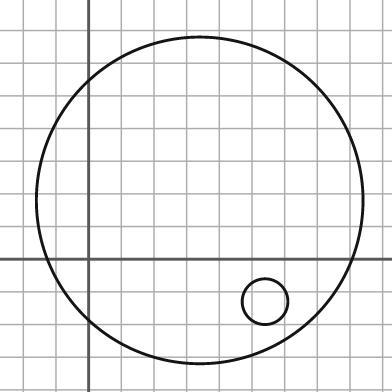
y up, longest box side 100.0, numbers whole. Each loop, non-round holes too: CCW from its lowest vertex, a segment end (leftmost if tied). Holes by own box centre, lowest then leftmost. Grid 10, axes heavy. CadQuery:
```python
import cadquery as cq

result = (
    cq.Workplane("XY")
    .moveTo(34.0, 18.0)
    .circle(50.0)
    .moveTo(54.0, -13.0)
    .circle(7.0)
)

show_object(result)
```